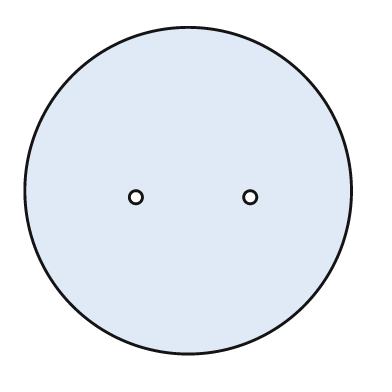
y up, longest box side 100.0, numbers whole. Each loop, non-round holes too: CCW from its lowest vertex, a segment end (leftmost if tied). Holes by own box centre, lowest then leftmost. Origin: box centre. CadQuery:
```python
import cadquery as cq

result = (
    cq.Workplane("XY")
    .moveTo(0.0, 0.0)
    .circle(50.0)
    .moveTo(-16.0, -2.0)
    .circle(2.0)
    .moveTo(19.0, -2.0)
    .circle(2.0)
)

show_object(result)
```